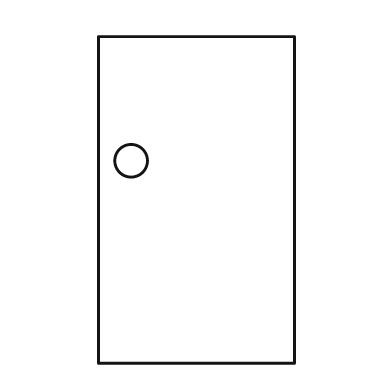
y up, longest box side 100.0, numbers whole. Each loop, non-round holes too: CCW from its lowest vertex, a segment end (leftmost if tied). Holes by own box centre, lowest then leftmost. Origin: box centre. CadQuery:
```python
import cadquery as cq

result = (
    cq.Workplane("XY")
    .moveTo(-30.0, -50.0)
    .lineTo(30.0, -50.0)
    .lineTo(30.0, 50.0)
    .lineTo(-30.0, 50.0)
    .close()
    .moveTo(-20.0, 12.0)
    .circle(5.0)
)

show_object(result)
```